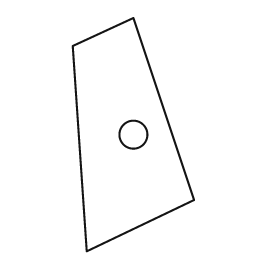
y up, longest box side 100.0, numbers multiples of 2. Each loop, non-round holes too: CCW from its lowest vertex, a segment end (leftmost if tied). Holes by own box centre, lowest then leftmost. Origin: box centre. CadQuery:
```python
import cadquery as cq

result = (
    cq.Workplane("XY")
    .moveTo(-20.0, -50.0)
    .lineTo(26.0, -28.0)
    .lineTo(0.0, 50.0)
    .lineTo(-26.0, 38.0)
    .close()
    .moveTo(0.0, 0.0)
    .circle(6.0)
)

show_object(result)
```